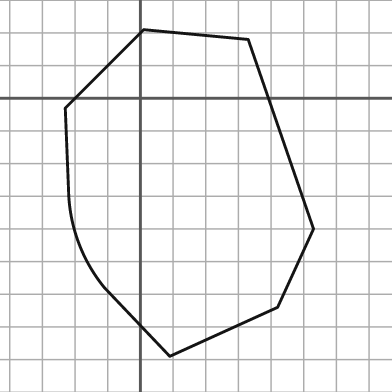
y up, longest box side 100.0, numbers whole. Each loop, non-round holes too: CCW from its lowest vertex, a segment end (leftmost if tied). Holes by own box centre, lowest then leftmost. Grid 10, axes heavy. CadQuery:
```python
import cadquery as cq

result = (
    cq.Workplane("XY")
    .moveTo(9.0, -79.0)
    .lineTo(42.0, -64.0)
    .lineTo(53.0, -40.0)
    .lineTo(33.0, 18.0)
    .lineTo(1.0, 21.0)
    .lineTo(-23.0, -3.0)
    .lineTo(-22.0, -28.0)
    .threePointArc((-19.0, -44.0), (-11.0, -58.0))
    .close()
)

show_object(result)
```